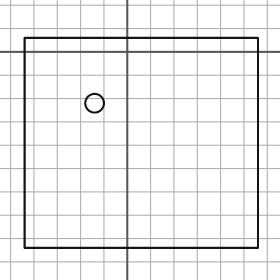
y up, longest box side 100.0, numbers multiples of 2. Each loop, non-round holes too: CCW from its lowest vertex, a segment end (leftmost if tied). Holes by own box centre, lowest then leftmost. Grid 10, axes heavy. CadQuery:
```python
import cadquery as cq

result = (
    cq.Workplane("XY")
    .moveTo(-44.0, -84.0)
    .lineTo(56.0, -84.0)
    .lineTo(56.0, 6.0)
    .lineTo(-44.0, 6.0)
    .close()
    .moveTo(-14.0, -22.0)
    .circle(4.0)
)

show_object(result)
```